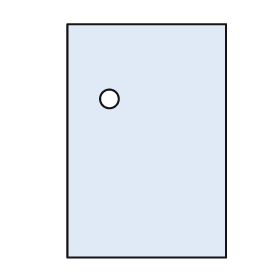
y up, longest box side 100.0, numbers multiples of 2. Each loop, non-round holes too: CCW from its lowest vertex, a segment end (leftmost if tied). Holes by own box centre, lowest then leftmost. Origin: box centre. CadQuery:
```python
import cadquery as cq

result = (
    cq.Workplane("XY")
    .moveTo(-34.0, -50.0)
    .lineTo(34.0, -50.0)
    .lineTo(34.0, 50.0)
    .lineTo(-34.0, 50.0)
    .close()
    .moveTo(-16.0, 18.0)
    .circle(4.0)
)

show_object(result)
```